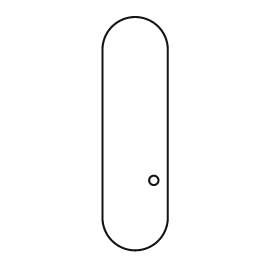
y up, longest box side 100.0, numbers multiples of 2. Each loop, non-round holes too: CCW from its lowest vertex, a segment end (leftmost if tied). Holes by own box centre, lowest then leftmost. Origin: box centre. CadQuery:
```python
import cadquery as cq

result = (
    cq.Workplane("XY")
    .moveTo(-14.0, -36.0)
    .threePointArc((0.0, -50.0), (14.0, -36.0))
    .lineTo(14.0, 36.0)
    .threePointArc((0.0, 50.0), (-14.0, 36.0))
    .close()
    .moveTo(8.0, -20.0)
    .circle(2.0)
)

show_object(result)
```